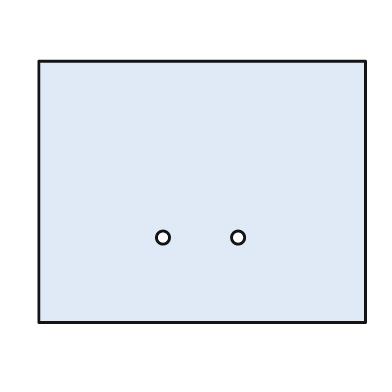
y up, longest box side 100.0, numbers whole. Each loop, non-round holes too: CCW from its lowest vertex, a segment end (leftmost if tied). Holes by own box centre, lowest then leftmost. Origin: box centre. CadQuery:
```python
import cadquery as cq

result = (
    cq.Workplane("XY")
    .moveTo(-50.0, -40.0)
    .lineTo(50.0, -40.0)
    .lineTo(50.0, 40.0)
    .lineTo(-50.0, 40.0)
    .close()
    .moveTo(-12.0, -14.0)
    .circle(2.0)
    .moveTo(11.0, -14.0)
    .circle(2.0)
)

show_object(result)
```